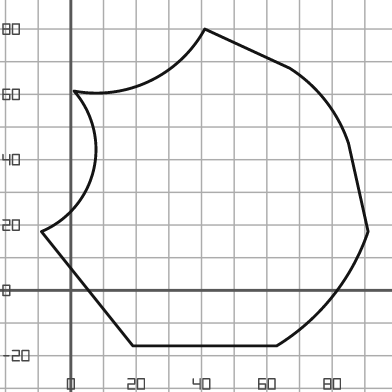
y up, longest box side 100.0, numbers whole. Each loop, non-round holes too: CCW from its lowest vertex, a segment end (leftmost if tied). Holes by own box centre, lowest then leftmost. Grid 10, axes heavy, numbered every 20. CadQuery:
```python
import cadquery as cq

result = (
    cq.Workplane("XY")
    .moveTo(19.0, -17.0)
    .lineTo(63.0, -17.0)
    .threePointArc((80.0, -2.0), (91.0, 18.0))
    .lineTo(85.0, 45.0)
    .threePointArc((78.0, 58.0), (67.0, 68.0))
    .lineTo(41.0, 80.0)
    .threePointArc((24.0, 64.0), (1.0, 61.0))
    .threePointArc((7.0, 37.0), (-9.0, 18.0))
    .close()
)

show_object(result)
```